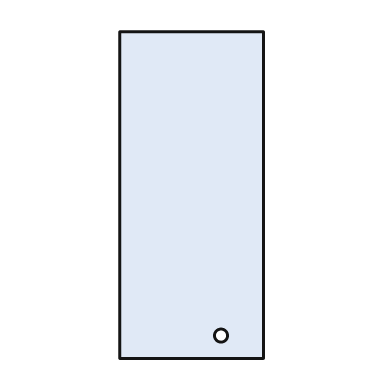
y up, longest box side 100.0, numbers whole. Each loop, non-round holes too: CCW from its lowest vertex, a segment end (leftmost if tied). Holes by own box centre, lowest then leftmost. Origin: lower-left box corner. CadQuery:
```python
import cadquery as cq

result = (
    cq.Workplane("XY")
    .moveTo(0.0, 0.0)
    .lineTo(44.0, 0.0)
    .lineTo(44.0, 100.0)
    .lineTo(0.0, 100.0)
    .close()
    .moveTo(31.0, 7.0)
    .circle(2.0)
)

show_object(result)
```